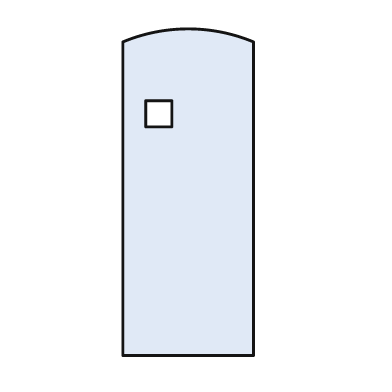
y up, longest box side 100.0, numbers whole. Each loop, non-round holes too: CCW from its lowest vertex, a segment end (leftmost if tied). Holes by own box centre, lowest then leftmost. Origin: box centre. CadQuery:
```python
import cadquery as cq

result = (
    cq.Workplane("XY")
    .moveTo(-20.0, -50.0)
    .lineTo(20.0, -50.0)
    .lineTo(20.0, 46.0)
    .threePointArc((0.0, 50.0), (-20.0, 46.0))
    .close()
    .moveTo(-13.0, 20.0)
    .lineTo(-5.0, 20.0)
    .lineTo(-5.0, 28.0)
    .lineTo(-13.0, 28.0)
    .close()
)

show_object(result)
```